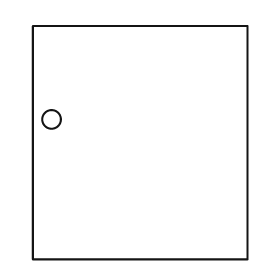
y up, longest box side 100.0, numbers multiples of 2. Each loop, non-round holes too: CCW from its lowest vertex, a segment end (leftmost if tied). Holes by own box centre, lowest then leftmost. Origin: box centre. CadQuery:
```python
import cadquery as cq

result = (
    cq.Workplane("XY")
    .moveTo(-46.0, -50.0)
    .lineTo(46.0, -50.0)
    .lineTo(46.0, 50.0)
    .lineTo(-46.0, 50.0)
    .close()
    .moveTo(-38.0, 10.0)
    .circle(4.0)
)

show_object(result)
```